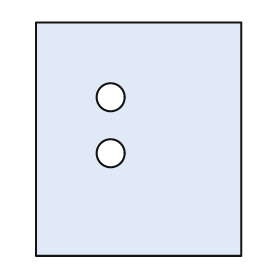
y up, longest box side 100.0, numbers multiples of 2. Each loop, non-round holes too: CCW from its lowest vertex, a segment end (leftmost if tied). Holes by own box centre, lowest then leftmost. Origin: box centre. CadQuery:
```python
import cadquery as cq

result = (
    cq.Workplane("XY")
    .moveTo(-44.0, -50.0)
    .lineTo(44.0, -50.0)
    .lineTo(44.0, 50.0)
    .lineTo(-44.0, 50.0)
    .close()
    .moveTo(-12.0, -6.0)
    .circle(6.0)
    .moveTo(-12.0, 18.0)
    .circle(6.0)
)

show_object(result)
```